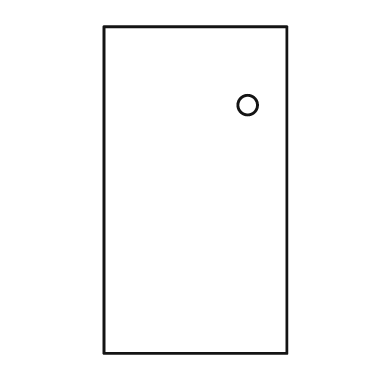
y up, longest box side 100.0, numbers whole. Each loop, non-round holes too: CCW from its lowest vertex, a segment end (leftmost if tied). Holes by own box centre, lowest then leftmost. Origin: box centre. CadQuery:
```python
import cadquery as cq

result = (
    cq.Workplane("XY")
    .moveTo(-28.0, -50.0)
    .lineTo(28.0, -50.0)
    .lineTo(28.0, 50.0)
    .lineTo(-28.0, 50.0)
    .close()
    .moveTo(16.0, 26.0)
    .circle(3.0)
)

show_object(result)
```